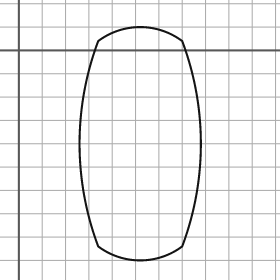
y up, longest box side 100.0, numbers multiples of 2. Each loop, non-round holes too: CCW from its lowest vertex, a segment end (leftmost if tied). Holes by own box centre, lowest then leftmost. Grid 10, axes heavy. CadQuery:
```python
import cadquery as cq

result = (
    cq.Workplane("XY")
    .moveTo(34.0, -84.0)
    .threePointArc((52.0, -90.0), (70.0, -84.0))
    .threePointArc((78.0, -40.0), (70.0, 4.0))
    .threePointArc((52.0, 10.0), (34.0, 4.0))
    .threePointArc((26.0, -40.0), (34.0, -84.0))
    .close()
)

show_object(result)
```